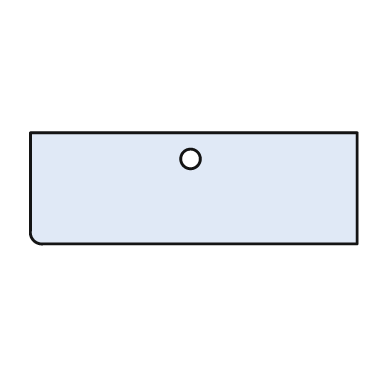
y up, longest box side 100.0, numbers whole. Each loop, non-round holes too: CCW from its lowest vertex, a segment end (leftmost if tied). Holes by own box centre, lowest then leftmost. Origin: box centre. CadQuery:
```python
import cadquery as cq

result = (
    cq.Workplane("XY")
    .moveTo(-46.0, -17.0)
    .lineTo(50.0, -17.0)
    .lineTo(50.0, 17.0)
    .lineTo(-50.0, 17.0)
    .lineTo(-50.0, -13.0)
    .threePointArc((-49.0, -16.0), (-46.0, -17.0))
    .close()
    .moveTo(-1.0, 9.0)
    .circle(3.0)
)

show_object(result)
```